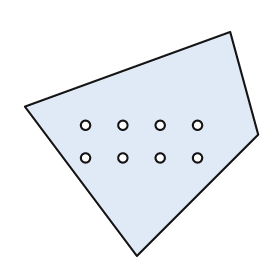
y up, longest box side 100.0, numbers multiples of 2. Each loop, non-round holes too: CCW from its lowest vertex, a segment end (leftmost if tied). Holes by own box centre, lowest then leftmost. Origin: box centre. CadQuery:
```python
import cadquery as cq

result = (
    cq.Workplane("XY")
    .moveTo(-2.0, -48.0)
    .lineTo(50.0, 4.0)
    .lineTo(38.0, 48.0)
    .lineTo(-50.0, 16.0)
    .close()
    .moveTo(-24.0, -6.0)
    .circle(2.0)
    .moveTo(-8.0, -6.0)
    .circle(2.0)
    .moveTo(8.0, -6.0)
    .circle(2.0)
    .moveTo(24.0, -6.0)
    .circle(2.0)
    .moveTo(-24.0, 8.0)
    .circle(2.0)
    .moveTo(-8.0, 8.0)
    .circle(2.0)
    .moveTo(8.0, 8.0)
    .circle(2.0)
    .moveTo(24.0, 8.0)
    .circle(2.0)
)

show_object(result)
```